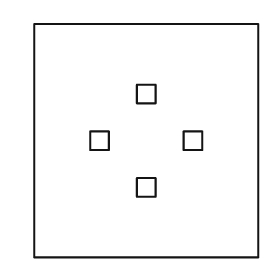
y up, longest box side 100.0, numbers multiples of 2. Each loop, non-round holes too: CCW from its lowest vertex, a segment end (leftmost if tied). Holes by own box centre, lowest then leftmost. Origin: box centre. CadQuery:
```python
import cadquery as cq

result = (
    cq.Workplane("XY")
    .moveTo(-48.0, -50.0)
    .lineTo(48.0, -50.0)
    .lineTo(48.0, 50.0)
    .lineTo(-48.0, 50.0)
    .close()
    .moveTo(-4.0, -24.0)
    .lineTo(4.0, -24.0)
    .lineTo(4.0, -16.0)
    .lineTo(-4.0, -16.0)
    .close()
    .moveTo(-24.0, -4.0)
    .lineTo(-16.0, -4.0)
    .lineTo(-16.0, 4.0)
    .lineTo(-24.0, 4.0)
    .close()
    .moveTo(16.0, -4.0)
    .lineTo(24.0, -4.0)
    .lineTo(24.0, 4.0)
    .lineTo(16.0, 4.0)
    .close()
    .moveTo(-4.0, 16.0)
    .lineTo(4.0, 16.0)
    .lineTo(4.0, 24.0)
    .lineTo(-4.0, 24.0)
    .close()
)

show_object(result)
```